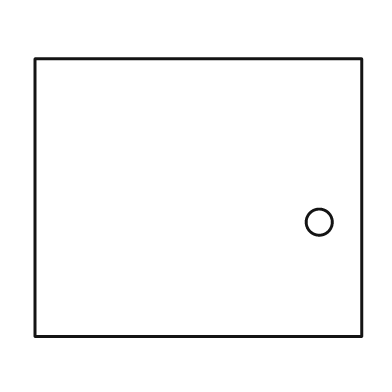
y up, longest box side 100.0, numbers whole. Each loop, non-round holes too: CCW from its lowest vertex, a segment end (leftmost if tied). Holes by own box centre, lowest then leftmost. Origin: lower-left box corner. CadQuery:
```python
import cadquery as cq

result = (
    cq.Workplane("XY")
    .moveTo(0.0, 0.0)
    .lineTo(100.0, 0.0)
    .lineTo(100.0, 85.0)
    .lineTo(0.0, 85.0)
    .close()
    .moveTo(87.0, 35.0)
    .circle(4.0)
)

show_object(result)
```